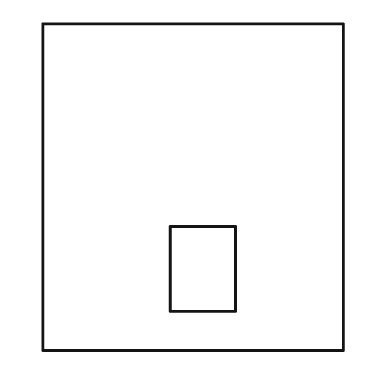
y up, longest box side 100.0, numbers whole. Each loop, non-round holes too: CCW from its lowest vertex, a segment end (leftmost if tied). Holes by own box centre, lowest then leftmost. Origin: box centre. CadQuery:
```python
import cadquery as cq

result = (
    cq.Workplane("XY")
    .moveTo(-46.0, -50.0)
    .lineTo(46.0, -50.0)
    .lineTo(46.0, 50.0)
    .lineTo(-46.0, 50.0)
    .close()
    .moveTo(-7.0, -38.0)
    .lineTo(13.0, -38.0)
    .lineTo(13.0, -12.0)
    .lineTo(-7.0, -12.0)
    .close()
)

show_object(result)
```